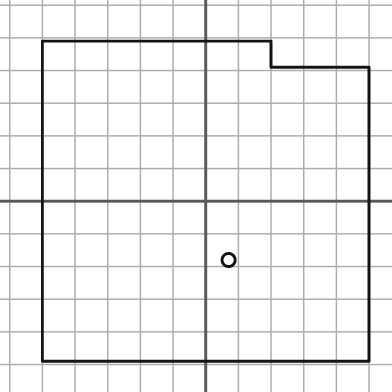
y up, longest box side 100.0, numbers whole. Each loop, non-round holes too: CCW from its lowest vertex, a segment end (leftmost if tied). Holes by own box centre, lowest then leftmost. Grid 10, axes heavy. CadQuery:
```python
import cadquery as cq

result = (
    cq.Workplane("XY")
    .moveTo(-50.0, -49.0)
    .lineTo(50.0, -49.0)
    .lineTo(50.0, 41.0)
    .lineTo(20.0, 41.0)
    .lineTo(20.0, 49.0)
    .lineTo(-50.0, 49.0)
    .close()
    .moveTo(7.0, -18.0)
    .circle(2.0)
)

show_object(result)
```